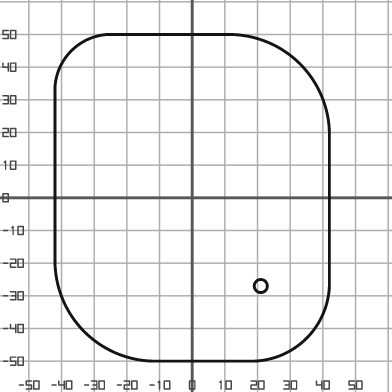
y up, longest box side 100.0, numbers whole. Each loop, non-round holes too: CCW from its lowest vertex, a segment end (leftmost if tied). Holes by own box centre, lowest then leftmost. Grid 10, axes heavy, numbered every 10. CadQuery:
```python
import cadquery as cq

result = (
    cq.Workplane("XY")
    .moveTo(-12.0, -50.0)
    .lineTo(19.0, -50.0)
    .threePointArc((35.0, -43.0), (42.0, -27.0))
    .lineTo(42.0, 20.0)
    .threePointArc((33.0, 41.0), (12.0, 50.0))
    .lineTo(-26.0, 50.0)
    .threePointArc((-37.0, 45.0), (-42.0, 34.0))
    .lineTo(-42.0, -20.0)
    .threePointArc((-33.0, -41.0), (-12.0, -50.0))
    .close()
    .moveTo(21.0, -27.0)
    .circle(2.0)
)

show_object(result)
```